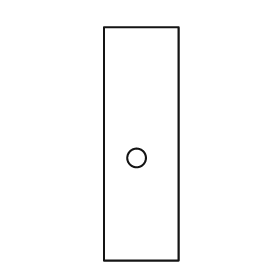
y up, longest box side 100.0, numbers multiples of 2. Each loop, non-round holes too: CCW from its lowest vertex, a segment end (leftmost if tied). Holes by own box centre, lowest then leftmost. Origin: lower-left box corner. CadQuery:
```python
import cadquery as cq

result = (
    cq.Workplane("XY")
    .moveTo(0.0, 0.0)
    .lineTo(32.0, 0.0)
    .lineTo(32.0, 100.0)
    .lineTo(0.0, 100.0)
    .close()
    .moveTo(14.0, 44.0)
    .circle(4.0)
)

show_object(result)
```